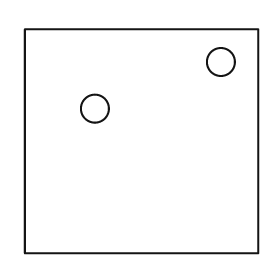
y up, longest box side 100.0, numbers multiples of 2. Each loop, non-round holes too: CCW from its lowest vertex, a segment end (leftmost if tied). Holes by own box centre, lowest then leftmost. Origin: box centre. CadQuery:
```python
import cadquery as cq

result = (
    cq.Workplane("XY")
    .moveTo(-50.0, -48.0)
    .lineTo(50.0, -48.0)
    .lineTo(50.0, 48.0)
    .lineTo(-50.0, 48.0)
    .close()
    .moveTo(-20.0, 14.0)
    .circle(6.0)
    .moveTo(34.0, 34.0)
    .circle(6.0)
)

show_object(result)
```